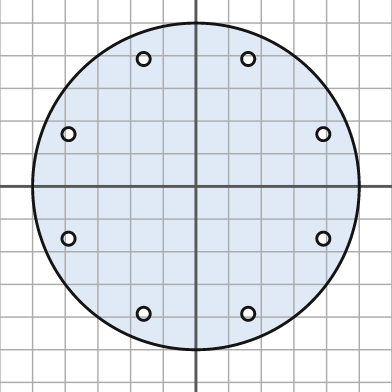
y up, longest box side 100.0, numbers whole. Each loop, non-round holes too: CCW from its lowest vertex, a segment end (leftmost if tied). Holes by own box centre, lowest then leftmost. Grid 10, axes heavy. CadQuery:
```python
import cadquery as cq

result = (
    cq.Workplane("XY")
    .moveTo(0.0, 0.0)
    .circle(50.0)
    .moveTo(-16.0, -39.0)
    .circle(2.0)
    .moveTo(16.0, -39.0)
    .circle(2.0)
    .moveTo(-39.0, -16.0)
    .circle(2.0)
    .moveTo(39.0, -16.0)
    .circle(2.0)
    .moveTo(-39.0, 16.0)
    .circle(2.0)
    .moveTo(39.0, 16.0)
    .circle(2.0)
    .moveTo(-16.0, 39.0)
    .circle(2.0)
    .moveTo(16.0, 39.0)
    .circle(2.0)
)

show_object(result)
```